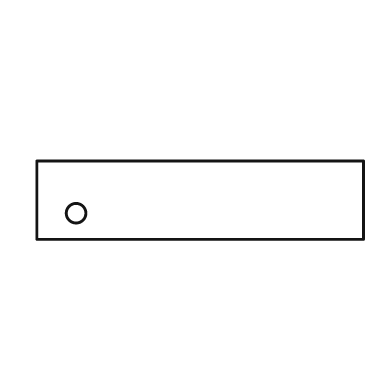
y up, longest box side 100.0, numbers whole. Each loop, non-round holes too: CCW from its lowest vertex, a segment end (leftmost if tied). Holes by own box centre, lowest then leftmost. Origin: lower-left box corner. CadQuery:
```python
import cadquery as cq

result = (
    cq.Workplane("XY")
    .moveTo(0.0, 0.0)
    .lineTo(100.0, 0.0)
    .lineTo(100.0, 24.0)
    .lineTo(0.0, 24.0)
    .close()
    .moveTo(12.0, 8.0)
    .circle(3.0)
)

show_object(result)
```